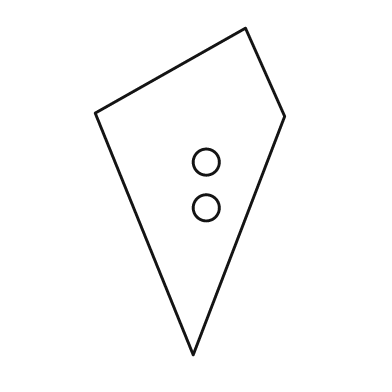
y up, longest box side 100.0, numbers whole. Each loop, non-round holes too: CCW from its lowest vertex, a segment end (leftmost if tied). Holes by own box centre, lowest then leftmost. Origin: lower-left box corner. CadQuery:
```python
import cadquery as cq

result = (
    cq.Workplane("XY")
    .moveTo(30.0, 0.0)
    .lineTo(58.0, 73.0)
    .lineTo(46.0, 100.0)
    .lineTo(0.0, 74.0)
    .close()
    .moveTo(34.0, 45.0)
    .circle(4.0)
    .moveTo(34.0, 59.0)
    .circle(4.0)
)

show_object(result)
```